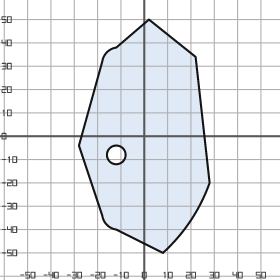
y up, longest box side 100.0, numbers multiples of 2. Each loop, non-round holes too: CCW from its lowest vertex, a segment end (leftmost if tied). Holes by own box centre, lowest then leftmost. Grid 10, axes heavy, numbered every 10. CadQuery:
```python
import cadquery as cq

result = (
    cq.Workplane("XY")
    .moveTo(8.0, -50.0)
    .threePointArc((20.0, -36.0), (28.0, -20.0))
    .lineTo(22.0, 34.0)
    .lineTo(2.0, 50.0)
    .lineTo(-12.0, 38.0)
    .threePointArc((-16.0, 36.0), (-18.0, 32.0))
    .lineTo(-28.0, -4.0)
    .lineTo(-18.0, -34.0)
    .threePointArc((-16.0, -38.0), (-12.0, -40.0))
    .close()
    .moveTo(-12.0, -8.0)
    .circle(4.0)
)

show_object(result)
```